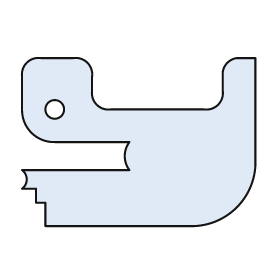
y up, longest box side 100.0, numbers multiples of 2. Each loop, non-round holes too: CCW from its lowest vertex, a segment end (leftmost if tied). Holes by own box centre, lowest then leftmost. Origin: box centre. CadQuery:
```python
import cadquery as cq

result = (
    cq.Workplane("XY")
    .moveTo(-40.0, -36.0)
    .lineTo(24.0, -36.0)
    .threePointArc((42.0, -28.0), (50.0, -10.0))
    .lineTo(50.0, 36.0)
    .lineTo(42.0, 36.0)
    .threePointArc((38.0, 34.0), (36.0, 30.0))
    .lineTo(36.0, 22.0)
    .threePointArc((34.0, 16.0), (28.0, 14.0))
    .lineTo(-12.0, 14.0)
    .threePointArc((-18.0, 16.0), (-20.0, 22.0))
    .lineTo(-20.0, 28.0)
    .threePointArc((-22.0, 34.0), (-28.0, 36.0))
    .lineTo(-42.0, 36.0)
    .threePointArc((-48.0, 34.0), (-50.0, 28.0))
    .lineTo(-50.0, 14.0)
    .threePointArc((-46.0, 4.0), (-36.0, 0.0))
    .lineTo(-4.0, 0.0)
    .threePointArc((-6.0, -6.0), (-4.0, -12.0))
    .lineTo(-50.0, -12.0)
    .threePointArc((-48.0, -16.0), (-50.0, -20.0))
    .lineTo(-44.0, -20.0)
    .lineTo(-44.0, -26.0)
    .lineTo(-40.0, -26.0)
    .close()
    .moveTo(-36.0, 14.0)
    .circle(4.0)
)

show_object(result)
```